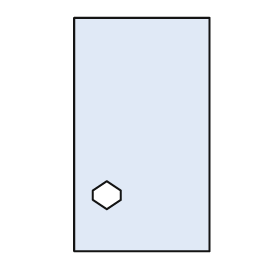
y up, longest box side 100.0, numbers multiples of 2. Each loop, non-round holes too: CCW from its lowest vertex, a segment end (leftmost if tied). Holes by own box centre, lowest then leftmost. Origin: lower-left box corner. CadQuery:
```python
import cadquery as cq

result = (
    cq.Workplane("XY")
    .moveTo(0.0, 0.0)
    .lineTo(58.0, 0.0)
    .lineTo(58.0, 100.0)
    .lineTo(0.0, 100.0)
    .close()
    .moveTo(14.0, 18.0)
    .lineTo(20.0, 22.0)
    .lineTo(20.0, 26.0)
    .lineTo(14.0, 30.0)
    .lineTo(8.0, 26.0)
    .lineTo(8.0, 22.0)
    .close()
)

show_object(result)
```